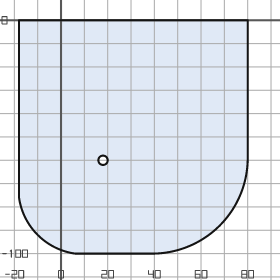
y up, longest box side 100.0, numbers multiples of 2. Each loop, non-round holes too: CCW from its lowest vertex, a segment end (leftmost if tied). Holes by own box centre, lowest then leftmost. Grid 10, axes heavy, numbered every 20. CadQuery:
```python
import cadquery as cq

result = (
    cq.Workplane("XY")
    .moveTo(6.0, -100.0)
    .lineTo(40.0, -100.0)
    .threePointArc((68.0, -88.0), (80.0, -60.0))
    .lineTo(80.0, 0.0)
    .lineTo(-18.0, 0.0)
    .lineTo(-18.0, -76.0)
    .threePointArc((-10.0, -92.0), (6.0, -100.0))
    .close()
    .moveTo(18.0, -60.0)
    .circle(2.0)
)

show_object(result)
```